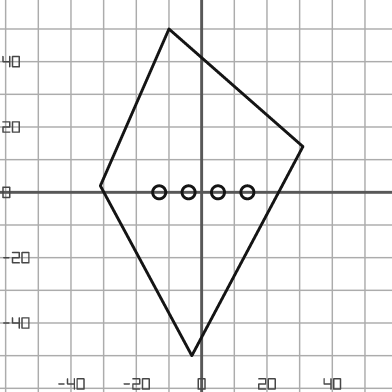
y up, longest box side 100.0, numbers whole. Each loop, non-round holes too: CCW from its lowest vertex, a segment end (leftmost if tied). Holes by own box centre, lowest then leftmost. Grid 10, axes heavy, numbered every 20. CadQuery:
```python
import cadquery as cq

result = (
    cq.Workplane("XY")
    .moveTo(-3.0, -50.0)
    .lineTo(31.0, 14.0)
    .lineTo(-10.0, 50.0)
    .lineTo(-31.0, 2.0)
    .close()
    .moveTo(-13.0, 0.0)
    .circle(2.0)
    .moveTo(-4.0, 0.0)
    .circle(2.0)
    .moveTo(5.0, 0.0)
    .circle(2.0)
    .moveTo(14.0, 0.0)
    .circle(2.0)
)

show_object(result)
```